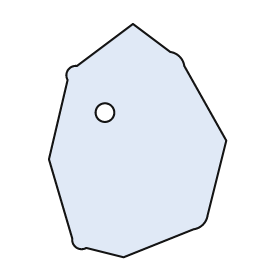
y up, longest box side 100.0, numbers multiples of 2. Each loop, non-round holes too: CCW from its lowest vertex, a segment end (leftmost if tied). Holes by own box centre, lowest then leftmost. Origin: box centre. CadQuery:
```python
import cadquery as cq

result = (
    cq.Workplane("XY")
    .moveTo(-6.0, -50.0)
    .lineTo(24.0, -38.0)
    .threePointArc((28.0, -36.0), (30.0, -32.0))
    .lineTo(38.0, 0.0)
    .lineTo(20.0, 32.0)
    .threePointArc((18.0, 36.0), (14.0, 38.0))
    .lineTo(-2.0, 50.0)
    .lineTo(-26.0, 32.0)
    .threePointArc((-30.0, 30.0), (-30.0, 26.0))
    .lineTo(-38.0, -8.0)
    .lineTo(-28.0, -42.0)
    .threePointArc((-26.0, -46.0), (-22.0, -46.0))
    .close()
    .moveTo(-14.0, 12.0)
    .circle(4.0)
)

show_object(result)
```